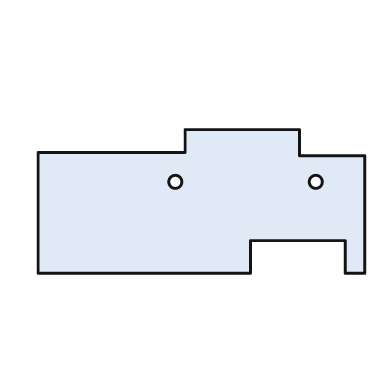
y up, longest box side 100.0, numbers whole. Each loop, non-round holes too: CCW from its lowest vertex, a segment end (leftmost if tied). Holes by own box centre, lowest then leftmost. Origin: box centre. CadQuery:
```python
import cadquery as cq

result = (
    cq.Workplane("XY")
    .moveTo(-50.0, -22.0)
    .lineTo(15.0, -22.0)
    .lineTo(15.0, -12.0)
    .lineTo(44.0, -12.0)
    .lineTo(44.0, -22.0)
    .lineTo(50.0, -22.0)
    .lineTo(50.0, 14.0)
    .lineTo(30.0, 14.0)
    .lineTo(30.0, 22.0)
    .lineTo(-5.0, 22.0)
    .lineTo(-5.0, 15.0)
    .lineTo(-50.0, 15.0)
    .close()
    .moveTo(-8.0, 6.0)
    .circle(2.0)
    .moveTo(35.0, 6.0)
    .circle(2.0)
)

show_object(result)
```